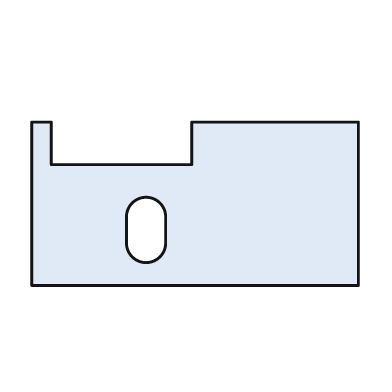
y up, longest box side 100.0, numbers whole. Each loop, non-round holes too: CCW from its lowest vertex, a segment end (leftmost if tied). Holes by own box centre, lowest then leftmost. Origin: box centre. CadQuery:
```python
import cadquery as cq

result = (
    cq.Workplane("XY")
    .moveTo(-50.0, -25.0)
    .lineTo(50.0, -25.0)
    .lineTo(50.0, 25.0)
    .lineTo(-1.0, 25.0)
    .lineTo(-1.0, 12.0)
    .lineTo(-44.0, 12.0)
    .lineTo(-44.0, 25.0)
    .lineTo(-50.0, 25.0)
    .close()
    .moveTo(-21.0, -12.0)
    .threePointArc((-15.0, -18.0), (-9.0, -12.0))
    .lineTo(-9.0, -4.0)
    .threePointArc((-15.0, 2.0), (-21.0, -4.0))
    .close()
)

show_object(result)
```